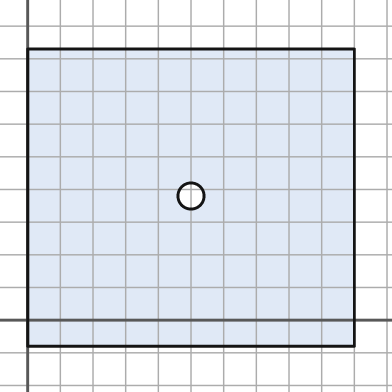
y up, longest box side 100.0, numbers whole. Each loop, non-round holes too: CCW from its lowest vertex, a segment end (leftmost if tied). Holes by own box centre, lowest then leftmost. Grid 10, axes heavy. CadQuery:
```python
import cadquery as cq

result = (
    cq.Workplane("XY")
    .moveTo(0.0, -8.0)
    .lineTo(100.0, -8.0)
    .lineTo(100.0, 83.0)
    .lineTo(0.0, 83.0)
    .close()
    .moveTo(50.0, 38.0)
    .circle(4.0)
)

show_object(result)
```